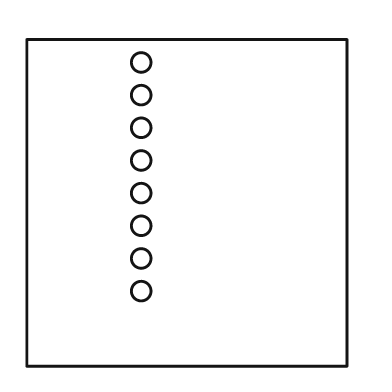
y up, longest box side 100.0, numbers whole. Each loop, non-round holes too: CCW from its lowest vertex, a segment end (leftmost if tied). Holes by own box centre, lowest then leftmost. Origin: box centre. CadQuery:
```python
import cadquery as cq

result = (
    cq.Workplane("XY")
    .moveTo(-49.0, -50.0)
    .lineTo(49.0, -50.0)
    .lineTo(49.0, 50.0)
    .lineTo(-49.0, 50.0)
    .close()
    .moveTo(-14.0, -27.0)
    .circle(3.0)
    .moveTo(-14.0, -17.0)
    .circle(3.0)
    .moveTo(-14.0, -7.0)
    .circle(3.0)
    .moveTo(-14.0, 3.0)
    .circle(3.0)
    .moveTo(-14.0, 13.0)
    .circle(3.0)
    .moveTo(-14.0, 23.0)
    .circle(3.0)
    .moveTo(-14.0, 33.0)
    .circle(3.0)
    .moveTo(-14.0, 43.0)
    .circle(3.0)
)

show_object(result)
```